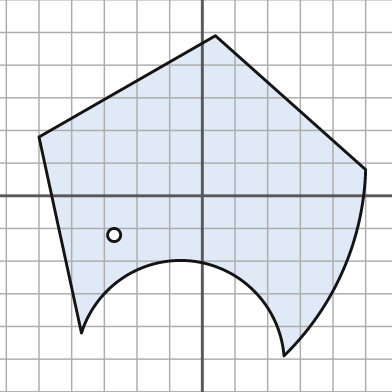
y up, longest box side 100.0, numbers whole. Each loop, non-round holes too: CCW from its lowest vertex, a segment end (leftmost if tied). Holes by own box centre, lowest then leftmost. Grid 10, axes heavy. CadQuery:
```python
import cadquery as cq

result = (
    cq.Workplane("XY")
    .moveTo(25.0, -49.0)
    .threePointArc((43.0, -23.0), (50.0, 8.0))
    .lineTo(4.0, 49.0)
    .lineTo(-50.0, 18.0)
    .lineTo(-37.0, -42.0)
    .threePointArc((-3.0, -20.0), (25.0, -49.0))
    .close()
    .moveTo(-27.0, -12.0)
    .circle(2.0)
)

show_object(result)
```